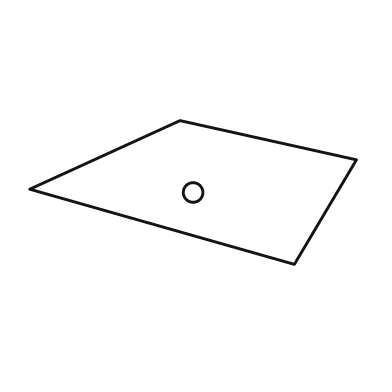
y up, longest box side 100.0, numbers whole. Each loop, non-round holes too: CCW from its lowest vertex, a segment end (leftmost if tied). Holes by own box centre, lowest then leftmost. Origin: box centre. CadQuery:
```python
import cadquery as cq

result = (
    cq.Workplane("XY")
    .moveTo(31.0, -22.0)
    .lineTo(50.0, 10.0)
    .lineTo(-4.0, 22.0)
    .lineTo(-50.0, 1.0)
    .close()
    .moveTo(0.0, 0.0)
    .circle(3.0)
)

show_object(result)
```